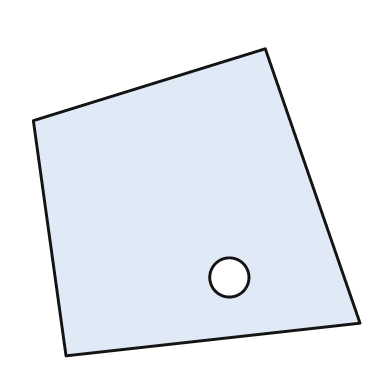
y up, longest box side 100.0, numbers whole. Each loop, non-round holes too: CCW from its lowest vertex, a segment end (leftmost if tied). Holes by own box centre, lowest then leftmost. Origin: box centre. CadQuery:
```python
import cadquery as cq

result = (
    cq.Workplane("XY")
    .moveTo(-40.0, -47.0)
    .lineTo(50.0, -37.0)
    .lineTo(21.0, 47.0)
    .lineTo(-50.0, 25.0)
    .close()
    .moveTo(10.0, -23.0)
    .circle(6.0)
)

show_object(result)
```